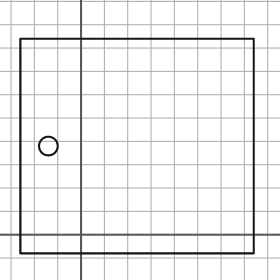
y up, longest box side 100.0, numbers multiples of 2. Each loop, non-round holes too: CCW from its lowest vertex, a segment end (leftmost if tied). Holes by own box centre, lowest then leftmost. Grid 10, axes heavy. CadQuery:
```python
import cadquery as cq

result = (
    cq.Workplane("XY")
    .moveTo(-26.0, -8.0)
    .lineTo(74.0, -8.0)
    .lineTo(74.0, 84.0)
    .lineTo(-26.0, 84.0)
    .close()
    .moveTo(-14.0, 38.0)
    .circle(4.0)
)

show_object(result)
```